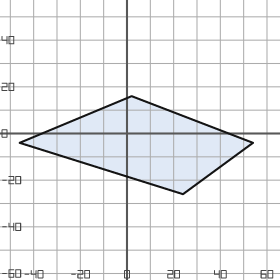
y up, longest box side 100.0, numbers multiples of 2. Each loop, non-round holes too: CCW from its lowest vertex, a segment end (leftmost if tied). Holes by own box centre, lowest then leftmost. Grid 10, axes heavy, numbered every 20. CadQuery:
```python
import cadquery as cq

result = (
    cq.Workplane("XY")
    .moveTo(24.0, -26.0)
    .lineTo(54.0, -4.0)
    .lineTo(2.0, 16.0)
    .lineTo(-46.0, -4.0)
    .close()
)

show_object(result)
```